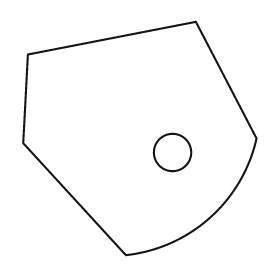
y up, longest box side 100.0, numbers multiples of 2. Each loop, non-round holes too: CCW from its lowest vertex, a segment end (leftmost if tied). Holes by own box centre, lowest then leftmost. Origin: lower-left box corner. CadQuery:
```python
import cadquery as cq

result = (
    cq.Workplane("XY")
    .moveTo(44.0, 0.0)
    .threePointArc((80.0, 16.0), (100.0, 50.0))
    .lineTo(74.0, 100.0)
    .lineTo(2.0, 86.0)
    .lineTo(0.0, 48.0)
    .close()
    .moveTo(64.0, 44.0)
    .circle(8.0)
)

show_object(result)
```